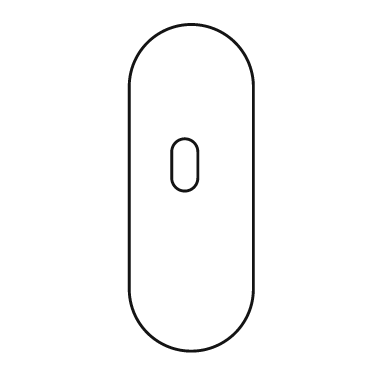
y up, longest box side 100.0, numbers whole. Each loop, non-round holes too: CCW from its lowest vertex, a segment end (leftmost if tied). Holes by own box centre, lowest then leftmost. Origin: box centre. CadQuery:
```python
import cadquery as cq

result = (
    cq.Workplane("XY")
    .moveTo(-19.0, -31.0)
    .threePointArc((0.0, -50.0), (19.0, -31.0))
    .lineTo(19.0, 31.0)
    .threePointArc((0.0, 50.0), (-19.0, 31.0))
    .close()
    .moveTo(-6.0, 3.0)
    .threePointArc((-2.0, -1.0), (2.0, 3.0))
    .lineTo(2.0, 11.0)
    .threePointArc((-2.0, 15.0), (-6.0, 11.0))
    .close()
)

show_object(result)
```